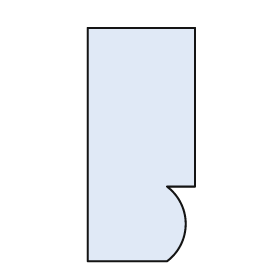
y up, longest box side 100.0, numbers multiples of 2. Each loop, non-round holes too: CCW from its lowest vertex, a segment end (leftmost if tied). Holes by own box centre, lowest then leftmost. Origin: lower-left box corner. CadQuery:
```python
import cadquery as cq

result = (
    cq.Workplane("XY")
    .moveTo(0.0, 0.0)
    .lineTo(34.0, 0.0)
    .threePointArc((42.0, 16.0), (34.0, 32.0))
    .lineTo(46.0, 32.0)
    .lineTo(46.0, 100.0)
    .lineTo(0.0, 100.0)
    .close()
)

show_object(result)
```